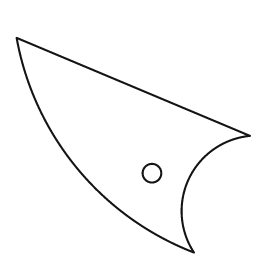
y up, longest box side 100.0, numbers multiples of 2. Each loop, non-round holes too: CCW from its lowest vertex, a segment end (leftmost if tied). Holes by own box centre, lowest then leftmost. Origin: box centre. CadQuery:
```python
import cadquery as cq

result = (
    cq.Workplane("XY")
    .moveTo(26.0, -46.0)
    .threePointArc((24.0, -14.0), (50.0, 4.0))
    .lineTo(-50.0, 46.0)
    .threePointArc((-24.0, -10.0), (26.0, -46.0))
    .close()
    .moveTo(8.0, -12.0)
    .circle(4.0)
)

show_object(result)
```